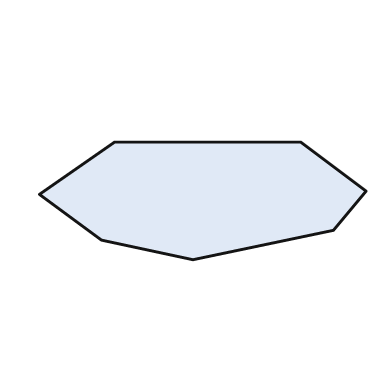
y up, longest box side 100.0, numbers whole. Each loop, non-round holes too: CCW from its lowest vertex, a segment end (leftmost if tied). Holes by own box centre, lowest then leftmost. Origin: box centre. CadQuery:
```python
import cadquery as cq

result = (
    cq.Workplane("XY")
    .moveTo(-3.0, -18.0)
    .lineTo(40.0, -9.0)
    .lineTo(50.0, 3.0)
    .lineTo(30.0, 18.0)
    .lineTo(-27.0, 18.0)
    .lineTo(-50.0, 2.0)
    .lineTo(-31.0, -12.0)
    .close()
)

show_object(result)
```